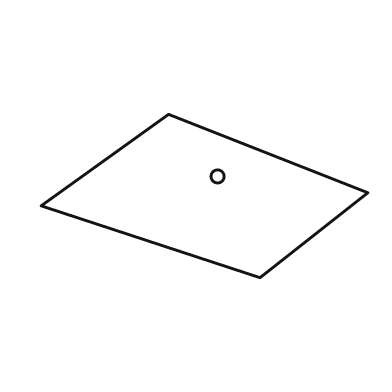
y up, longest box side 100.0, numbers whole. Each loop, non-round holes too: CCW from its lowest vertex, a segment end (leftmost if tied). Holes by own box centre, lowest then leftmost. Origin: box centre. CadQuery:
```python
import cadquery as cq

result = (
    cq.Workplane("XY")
    .moveTo(17.0, -25.0)
    .lineTo(50.0, 1.0)
    .lineTo(-11.0, 25.0)
    .lineTo(-50.0, -3.0)
    .close()
    .moveTo(4.0, 6.0)
    .circle(2.0)
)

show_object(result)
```